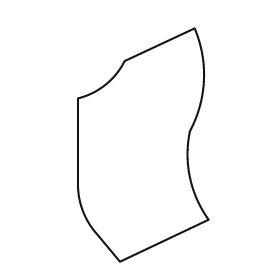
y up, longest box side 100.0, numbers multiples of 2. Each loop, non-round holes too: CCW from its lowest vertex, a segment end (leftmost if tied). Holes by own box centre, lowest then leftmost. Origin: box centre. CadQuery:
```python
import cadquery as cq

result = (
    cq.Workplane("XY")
    .moveTo(-10.0, -50.0)
    .lineTo(28.0, -32.0)
    .threePointArc((20.0, -14.0), (20.0, 6.0))
    .threePointArc((26.0, 28.0), (22.0, 50.0))
    .lineTo(-8.0, 36.0)
    .threePointArc((-16.0, 26.0), (-28.0, 20.0))
    .lineTo(-28.0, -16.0)
    .threePointArc((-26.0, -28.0), (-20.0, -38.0))
    .close()
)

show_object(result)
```